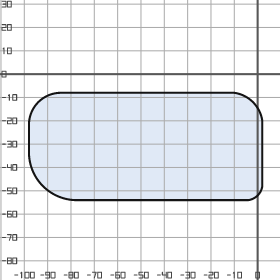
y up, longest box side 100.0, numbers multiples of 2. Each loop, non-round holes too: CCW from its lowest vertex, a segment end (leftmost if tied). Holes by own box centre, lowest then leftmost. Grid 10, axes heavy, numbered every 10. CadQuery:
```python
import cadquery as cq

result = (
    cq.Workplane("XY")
    .moveTo(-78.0, -54.0)
    .lineTo(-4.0, -54.0)
    .threePointArc((0.0, -52.0), (2.0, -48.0))
    .lineTo(2.0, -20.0)
    .threePointArc((-2.0, -12.0), (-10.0, -8.0))
    .lineTo(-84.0, -8.0)
    .threePointArc((-94.0, -12.0), (-98.0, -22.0))
    .lineTo(-98.0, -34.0)
    .threePointArc((-92.0, -48.0), (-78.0, -54.0))
    .close()
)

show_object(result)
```